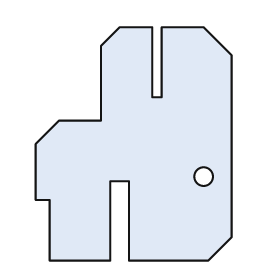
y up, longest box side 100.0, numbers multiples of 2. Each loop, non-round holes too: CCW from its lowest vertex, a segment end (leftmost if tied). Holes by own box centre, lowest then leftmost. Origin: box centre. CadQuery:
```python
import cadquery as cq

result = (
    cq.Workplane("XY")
    .moveTo(-36.0, -50.0)
    .lineTo(-10.0, -50.0)
    .lineTo(-10.0, -16.0)
    .lineTo(-2.0, -16.0)
    .lineTo(-2.0, -50.0)
    .lineTo(32.0, -50.0)
    .lineTo(42.0, -40.0)
    .lineTo(42.0, 38.0)
    .lineTo(30.0, 50.0)
    .lineTo(12.0, 50.0)
    .lineTo(12.0, 20.0)
    .lineTo(8.0, 20.0)
    .lineTo(8.0, 50.0)
    .lineTo(-6.0, 50.0)
    .lineTo(-14.0, 42.0)
    .lineTo(-14.0, 10.0)
    .lineTo(-32.0, 10.0)
    .lineTo(-42.0, 0.0)
    .lineTo(-42.0, -24.0)
    .lineTo(-36.0, -24.0)
    .close()
    .moveTo(30.0, -14.0)
    .circle(4.0)
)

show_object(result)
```